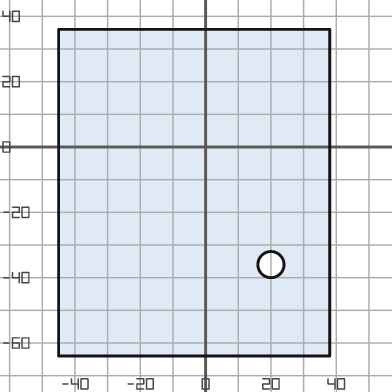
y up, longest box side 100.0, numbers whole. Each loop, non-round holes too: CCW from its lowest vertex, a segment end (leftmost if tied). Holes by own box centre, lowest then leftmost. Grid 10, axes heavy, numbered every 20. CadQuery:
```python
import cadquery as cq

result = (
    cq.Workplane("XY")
    .moveTo(-45.0, -64.0)
    .lineTo(38.0, -64.0)
    .lineTo(38.0, 36.0)
    .lineTo(-45.0, 36.0)
    .close()
    .moveTo(20.0, -36.0)
    .circle(4.0)
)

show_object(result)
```